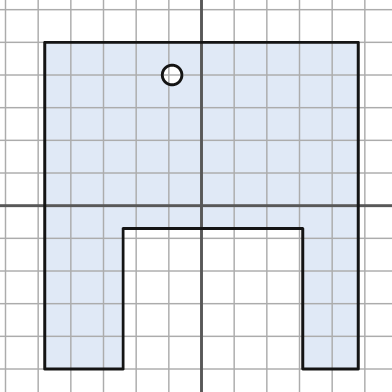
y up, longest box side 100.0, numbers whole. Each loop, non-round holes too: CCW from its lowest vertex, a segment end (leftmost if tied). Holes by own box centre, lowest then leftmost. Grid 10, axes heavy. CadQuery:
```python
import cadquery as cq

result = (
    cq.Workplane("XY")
    .moveTo(-48.0, -50.0)
    .lineTo(-24.0, -50.0)
    .lineTo(-24.0, -7.0)
    .lineTo(31.0, -7.0)
    .lineTo(31.0, -50.0)
    .lineTo(48.0, -50.0)
    .lineTo(48.0, 50.0)
    .lineTo(-48.0, 50.0)
    .close()
    .moveTo(-9.0, 40.0)
    .circle(3.0)
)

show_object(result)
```